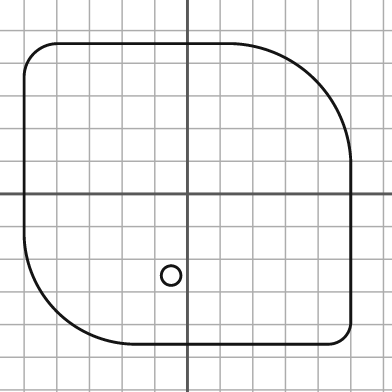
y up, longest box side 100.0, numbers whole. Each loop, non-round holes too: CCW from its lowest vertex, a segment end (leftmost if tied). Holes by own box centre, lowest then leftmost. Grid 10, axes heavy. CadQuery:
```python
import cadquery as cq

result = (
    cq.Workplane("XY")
    .moveTo(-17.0, -46.0)
    .lineTo(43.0, -46.0)
    .threePointArc((48.0, -44.0), (50.0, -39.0))
    .lineTo(50.0, 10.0)
    .threePointArc((39.0, 35.0), (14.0, 46.0))
    .lineTo(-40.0, 46.0)
    .threePointArc((-47.0, 43.0), (-50.0, 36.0))
    .lineTo(-50.0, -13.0)
    .threePointArc((-40.0, -36.0), (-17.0, -46.0))
    .close()
    .moveTo(-5.0, -25.0)
    .circle(3.0)
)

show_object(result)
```